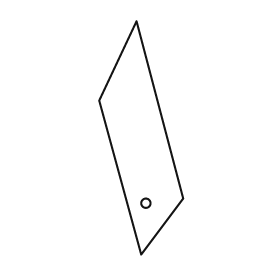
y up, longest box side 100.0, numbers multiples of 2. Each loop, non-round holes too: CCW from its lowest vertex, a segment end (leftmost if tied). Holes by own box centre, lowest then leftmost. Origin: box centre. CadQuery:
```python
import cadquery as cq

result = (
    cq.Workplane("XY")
    .moveTo(0.0, -50.0)
    .lineTo(18.0, -26.0)
    .lineTo(-2.0, 50.0)
    .lineTo(-18.0, 16.0)
    .close()
    .moveTo(2.0, -28.0)
    .circle(2.0)
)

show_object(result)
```